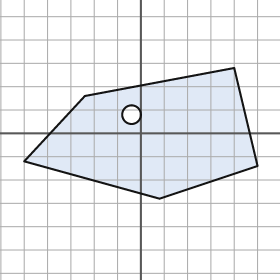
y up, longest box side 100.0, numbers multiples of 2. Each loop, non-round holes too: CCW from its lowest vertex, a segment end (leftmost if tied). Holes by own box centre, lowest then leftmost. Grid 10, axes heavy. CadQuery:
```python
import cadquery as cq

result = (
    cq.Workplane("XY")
    .moveTo(8.0, -28.0)
    .lineTo(50.0, -14.0)
    .lineTo(40.0, 28.0)
    .lineTo(-24.0, 16.0)
    .lineTo(-50.0, -12.0)
    .close()
    .moveTo(-4.0, 8.0)
    .circle(4.0)
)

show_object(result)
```